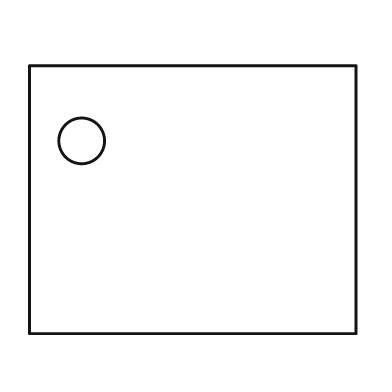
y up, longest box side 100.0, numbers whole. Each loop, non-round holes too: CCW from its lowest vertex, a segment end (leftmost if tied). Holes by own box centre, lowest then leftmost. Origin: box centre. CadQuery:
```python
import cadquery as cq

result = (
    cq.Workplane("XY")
    .moveTo(-50.0, -41.0)
    .lineTo(50.0, -41.0)
    .lineTo(50.0, 41.0)
    .lineTo(-50.0, 41.0)
    .close()
    .moveTo(-34.0, 18.0)
    .circle(7.0)
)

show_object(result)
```